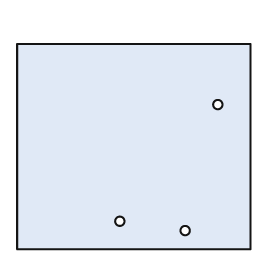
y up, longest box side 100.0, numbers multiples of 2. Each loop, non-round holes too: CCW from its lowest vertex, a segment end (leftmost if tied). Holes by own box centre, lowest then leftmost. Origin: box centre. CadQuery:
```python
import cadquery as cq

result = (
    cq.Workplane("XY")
    .moveTo(-50.0, -44.0)
    .lineTo(50.0, -44.0)
    .lineTo(50.0, 44.0)
    .lineTo(-50.0, 44.0)
    .close()
    .moveTo(22.0, -36.0)
    .circle(2.0)
    .moveTo(-6.0, -32.0)
    .circle(2.0)
    .moveTo(36.0, 18.0)
    .circle(2.0)
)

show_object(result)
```